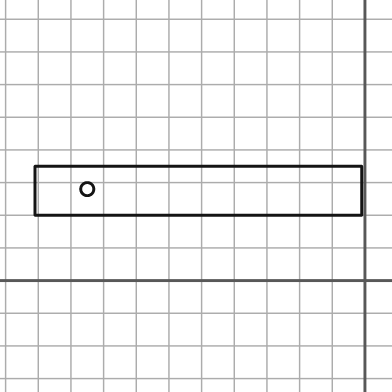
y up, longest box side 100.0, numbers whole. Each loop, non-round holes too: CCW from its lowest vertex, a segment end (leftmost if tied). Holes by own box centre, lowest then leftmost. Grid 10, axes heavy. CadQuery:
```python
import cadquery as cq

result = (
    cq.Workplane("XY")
    .moveTo(-101.0, 20.0)
    .lineTo(-1.0, 20.0)
    .lineTo(-1.0, 35.0)
    .lineTo(-101.0, 35.0)
    .close()
    .moveTo(-85.0, 28.0)
    .circle(2.0)
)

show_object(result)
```